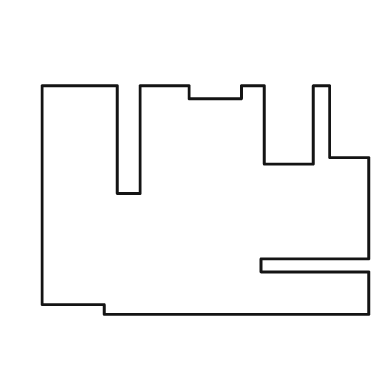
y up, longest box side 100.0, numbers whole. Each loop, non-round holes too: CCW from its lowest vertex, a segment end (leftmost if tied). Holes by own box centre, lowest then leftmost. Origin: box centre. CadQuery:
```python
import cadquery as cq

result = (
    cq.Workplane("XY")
    .moveTo(-31.0, -35.0)
    .lineTo(50.0, -35.0)
    .lineTo(50.0, -22.0)
    .lineTo(17.0, -22.0)
    .lineTo(17.0, -18.0)
    .lineTo(50.0, -18.0)
    .lineTo(50.0, 13.0)
    .lineTo(38.0, 13.0)
    .lineTo(38.0, 35.0)
    .lineTo(33.0, 35.0)
    .lineTo(33.0, 11.0)
    .lineTo(18.0, 11.0)
    .lineTo(18.0, 35.0)
    .lineTo(11.0, 35.0)
    .lineTo(11.0, 31.0)
    .lineTo(-5.0, 31.0)
    .lineTo(-5.0, 35.0)
    .lineTo(-20.0, 35.0)
    .lineTo(-20.0, 2.0)
    .lineTo(-27.0, 2.0)
    .lineTo(-27.0, 35.0)
    .lineTo(-50.0, 35.0)
    .lineTo(-50.0, -32.0)
    .lineTo(-31.0, -32.0)
    .close()
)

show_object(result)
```